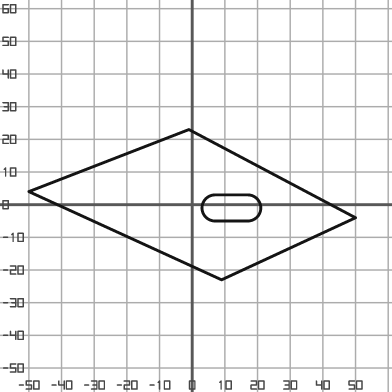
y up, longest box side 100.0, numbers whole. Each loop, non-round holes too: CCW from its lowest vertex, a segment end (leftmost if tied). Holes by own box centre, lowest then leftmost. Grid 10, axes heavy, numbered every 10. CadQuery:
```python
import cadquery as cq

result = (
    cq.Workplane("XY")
    .moveTo(9.0, -23.0)
    .lineTo(50.0, -4.0)
    .lineTo(-1.0, 23.0)
    .lineTo(-50.0, 4.0)
    .close()
    .moveTo(7.0, -5.0)
    .lineTo(17.0, -5.0)
    .threePointArc((21.0, -1.0), (17.0, 3.0))
    .lineTo(7.0, 3.0)
    .threePointArc((3.0, -1.0), (7.0, -5.0))
    .close()
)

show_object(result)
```